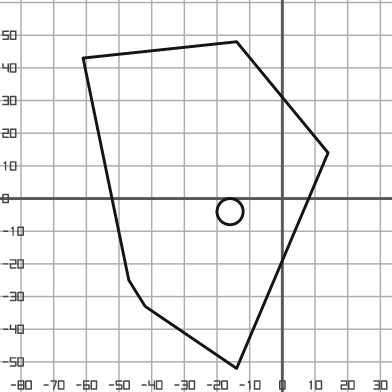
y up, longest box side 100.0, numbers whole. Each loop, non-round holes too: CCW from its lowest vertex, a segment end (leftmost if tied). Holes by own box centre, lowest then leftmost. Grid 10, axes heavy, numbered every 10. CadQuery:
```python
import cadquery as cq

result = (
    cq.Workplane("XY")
    .moveTo(-14.0, -52.0)
    .lineTo(14.0, 14.0)
    .lineTo(-14.0, 48.0)
    .lineTo(-61.0, 43.0)
    .lineTo(-47.0, -25.0)
    .lineTo(-42.0, -33.0)
    .close()
    .moveTo(-16.0, -4.0)
    .circle(4.0)
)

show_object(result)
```